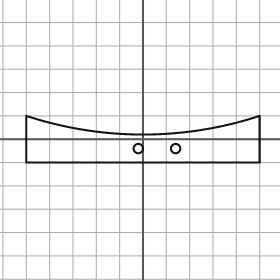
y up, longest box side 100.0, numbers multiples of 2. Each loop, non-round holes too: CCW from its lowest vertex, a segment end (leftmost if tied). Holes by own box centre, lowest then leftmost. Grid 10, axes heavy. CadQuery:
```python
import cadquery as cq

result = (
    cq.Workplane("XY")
    .moveTo(-50.0, -10.0)
    .lineTo(50.0, -10.0)
    .lineTo(50.0, 10.0)
    .threePointArc((0.0, 2.0), (-50.0, 10.0))
    .close()
    .moveTo(-2.0, -4.0)
    .circle(2.0)
    .moveTo(14.0, -4.0)
    .circle(2.0)
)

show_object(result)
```